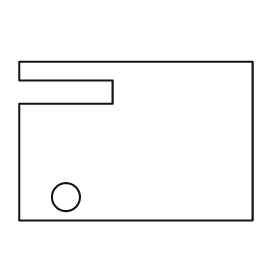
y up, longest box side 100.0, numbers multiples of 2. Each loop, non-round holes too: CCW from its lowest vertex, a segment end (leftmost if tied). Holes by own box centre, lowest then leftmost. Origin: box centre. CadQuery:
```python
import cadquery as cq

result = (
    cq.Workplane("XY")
    .moveTo(-50.0, -34.0)
    .lineTo(50.0, -34.0)
    .lineTo(50.0, 34.0)
    .lineTo(-50.0, 34.0)
    .lineTo(-50.0, 26.0)
    .lineTo(-10.0, 26.0)
    .lineTo(-10.0, 16.0)
    .lineTo(-50.0, 16.0)
    .close()
    .moveTo(-30.0, -24.0)
    .circle(6.0)
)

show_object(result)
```